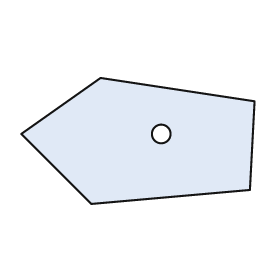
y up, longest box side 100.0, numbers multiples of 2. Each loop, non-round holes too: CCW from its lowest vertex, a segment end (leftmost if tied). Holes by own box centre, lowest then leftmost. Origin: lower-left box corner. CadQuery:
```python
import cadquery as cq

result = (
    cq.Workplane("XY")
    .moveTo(30.0, 0.0)
    .lineTo(98.0, 6.0)
    .lineTo(100.0, 44.0)
    .lineTo(34.0, 54.0)
    .lineTo(0.0, 30.0)
    .close()
    .moveTo(60.0, 30.0)
    .circle(4.0)
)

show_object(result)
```